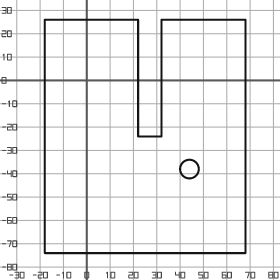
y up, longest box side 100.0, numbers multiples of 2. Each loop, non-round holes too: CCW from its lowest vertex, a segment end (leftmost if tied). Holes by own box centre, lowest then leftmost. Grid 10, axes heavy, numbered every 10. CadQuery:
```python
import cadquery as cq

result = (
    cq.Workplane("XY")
    .moveTo(-18.0, -74.0)
    .lineTo(68.0, -74.0)
    .lineTo(68.0, 26.0)
    .lineTo(32.0, 26.0)
    .lineTo(32.0, -24.0)
    .lineTo(22.0, -24.0)
    .lineTo(22.0, 26.0)
    .lineTo(-18.0, 26.0)
    .close()
    .moveTo(44.0, -38.0)
    .circle(4.0)
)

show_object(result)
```